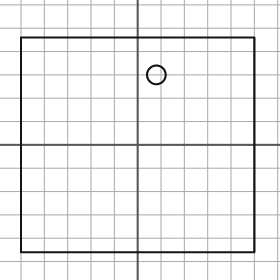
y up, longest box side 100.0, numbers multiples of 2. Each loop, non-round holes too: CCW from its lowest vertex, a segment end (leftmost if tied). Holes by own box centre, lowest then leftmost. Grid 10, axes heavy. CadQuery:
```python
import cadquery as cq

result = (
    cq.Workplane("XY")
    .moveTo(-50.0, -46.0)
    .lineTo(50.0, -46.0)
    .lineTo(50.0, 46.0)
    .lineTo(-50.0, 46.0)
    .close()
    .moveTo(8.0, 30.0)
    .circle(4.0)
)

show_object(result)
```